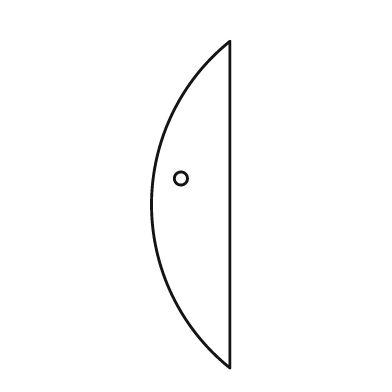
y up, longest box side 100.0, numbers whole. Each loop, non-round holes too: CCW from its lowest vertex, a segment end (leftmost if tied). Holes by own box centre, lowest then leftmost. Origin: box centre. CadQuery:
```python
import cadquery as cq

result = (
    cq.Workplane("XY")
    .moveTo(12.0, -50.0)
    .lineTo(12.0, 50.0)
    .threePointArc((-12.0, 0.0), (12.0, -50.0))
    .close()
    .moveTo(-3.0, 8.0)
    .circle(2.0)
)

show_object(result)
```